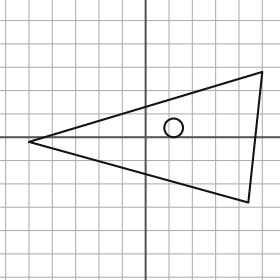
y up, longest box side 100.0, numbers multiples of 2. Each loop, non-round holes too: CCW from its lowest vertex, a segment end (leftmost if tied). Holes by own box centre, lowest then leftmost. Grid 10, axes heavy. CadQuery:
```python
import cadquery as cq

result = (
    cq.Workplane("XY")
    .moveTo(44.0, -28.0)
    .lineTo(50.0, 28.0)
    .lineTo(-50.0, -2.0)
    .close()
    .moveTo(12.0, 4.0)
    .circle(4.0)
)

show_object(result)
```